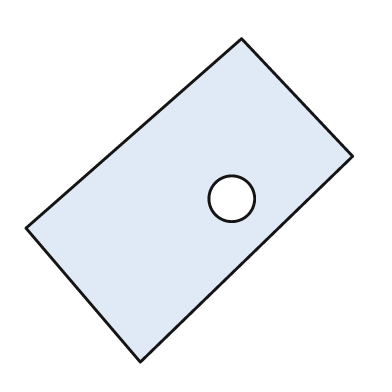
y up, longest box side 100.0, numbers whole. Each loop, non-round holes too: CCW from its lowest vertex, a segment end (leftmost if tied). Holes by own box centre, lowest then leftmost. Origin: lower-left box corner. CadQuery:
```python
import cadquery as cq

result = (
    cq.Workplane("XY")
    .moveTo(35.0, 0.0)
    .lineTo(100.0, 63.0)
    .lineTo(66.0, 99.0)
    .lineTo(0.0, 41.0)
    .close()
    .moveTo(63.0, 50.0)
    .circle(7.0)
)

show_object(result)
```